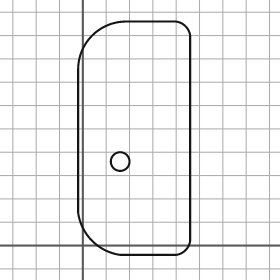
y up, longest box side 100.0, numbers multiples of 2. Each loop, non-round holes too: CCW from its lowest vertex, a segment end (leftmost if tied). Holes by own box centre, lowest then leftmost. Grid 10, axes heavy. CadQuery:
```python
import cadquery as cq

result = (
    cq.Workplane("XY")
    .moveTo(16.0, -4.0)
    .lineTo(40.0, -4.0)
    .threePointArc((44.0, -2.0), (46.0, 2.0))
    .lineTo(46.0, 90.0)
    .threePointArc((44.0, 94.0), (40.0, 96.0))
    .lineTo(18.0, 96.0)
    .threePointArc((4.0, 90.0), (-2.0, 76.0))
    .lineTo(-2.0, 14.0)
    .threePointArc((4.0, 2.0), (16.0, -4.0))
    .close()
    .moveTo(16.0, 36.0)
    .circle(4.0)
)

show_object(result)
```